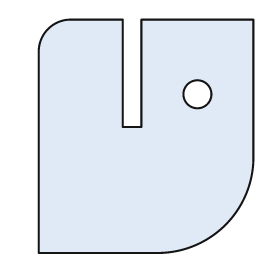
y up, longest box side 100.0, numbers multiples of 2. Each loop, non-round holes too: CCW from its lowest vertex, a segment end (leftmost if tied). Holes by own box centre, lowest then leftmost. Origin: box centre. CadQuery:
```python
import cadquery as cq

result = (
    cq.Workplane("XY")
    .moveTo(-46.0, -50.0)
    .lineTo(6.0, -50.0)
    .threePointArc((34.0, -38.0), (46.0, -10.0))
    .lineTo(46.0, 50.0)
    .lineTo(-2.0, 50.0)
    .lineTo(-2.0, 4.0)
    .lineTo(-10.0, 4.0)
    .lineTo(-10.0, 50.0)
    .lineTo(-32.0, 50.0)
    .threePointArc((-42.0, 46.0), (-46.0, 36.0))
    .close()
    .moveTo(22.0, 18.0)
    .circle(6.0)
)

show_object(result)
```